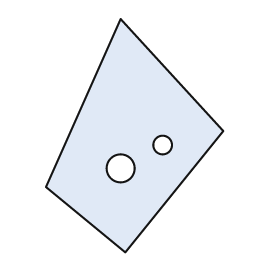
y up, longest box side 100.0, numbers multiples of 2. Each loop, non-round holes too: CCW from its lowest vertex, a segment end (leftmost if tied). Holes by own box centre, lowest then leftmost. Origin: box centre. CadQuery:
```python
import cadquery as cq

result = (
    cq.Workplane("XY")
    .moveTo(-4.0, -50.0)
    .lineTo(38.0, 2.0)
    .lineTo(-6.0, 50.0)
    .lineTo(-38.0, -22.0)
    .close()
    .moveTo(-6.0, -14.0)
    .circle(6.0)
    .moveTo(12.0, -4.0)
    .circle(4.0)
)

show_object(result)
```